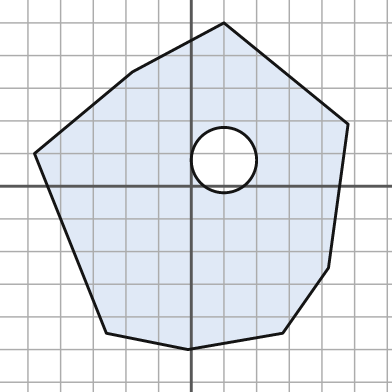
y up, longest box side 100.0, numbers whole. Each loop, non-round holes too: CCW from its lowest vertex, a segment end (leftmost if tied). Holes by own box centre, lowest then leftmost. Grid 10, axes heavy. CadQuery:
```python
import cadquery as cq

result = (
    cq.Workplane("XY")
    .moveTo(-1.0, -50.0)
    .lineTo(28.0, -45.0)
    .lineTo(42.0, -25.0)
    .lineTo(48.0, 19.0)
    .lineTo(10.0, 50.0)
    .lineTo(-18.0, 35.0)
    .lineTo(-48.0, 10.0)
    .lineTo(-26.0, -45.0)
    .close()
    .moveTo(10.0, 8.0)
    .circle(10.0)
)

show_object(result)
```